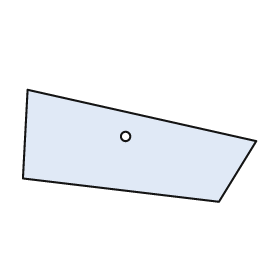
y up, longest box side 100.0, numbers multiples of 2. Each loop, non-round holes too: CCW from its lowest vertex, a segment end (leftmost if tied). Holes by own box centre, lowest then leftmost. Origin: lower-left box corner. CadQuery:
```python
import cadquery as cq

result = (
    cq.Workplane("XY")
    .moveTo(84.0, 0.0)
    .lineTo(100.0, 26.0)
    .lineTo(2.0, 48.0)
    .lineTo(0.0, 10.0)
    .close()
    .moveTo(44.0, 28.0)
    .circle(2.0)
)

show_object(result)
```